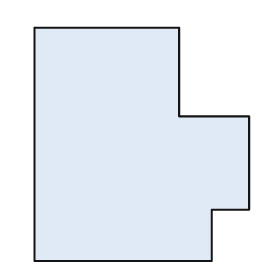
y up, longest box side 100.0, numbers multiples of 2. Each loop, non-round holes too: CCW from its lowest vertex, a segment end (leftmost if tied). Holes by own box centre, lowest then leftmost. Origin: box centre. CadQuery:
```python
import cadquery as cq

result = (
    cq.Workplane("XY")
    .moveTo(-46.0, -50.0)
    .lineTo(30.0, -50.0)
    .lineTo(30.0, -28.0)
    .lineTo(46.0, -28.0)
    .lineTo(46.0, 12.0)
    .lineTo(16.0, 12.0)
    .lineTo(16.0, 50.0)
    .lineTo(-46.0, 50.0)
    .close()
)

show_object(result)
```